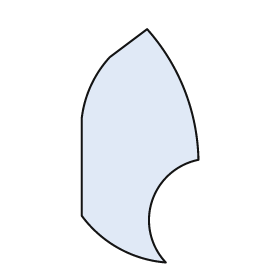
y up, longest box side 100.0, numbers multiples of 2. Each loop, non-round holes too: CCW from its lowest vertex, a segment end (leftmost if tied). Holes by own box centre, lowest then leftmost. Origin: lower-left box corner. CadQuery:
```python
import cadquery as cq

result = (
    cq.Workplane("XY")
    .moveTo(36.0, 0.0)
    .threePointArc((30.0, 26.0), (50.0, 44.0))
    .threePointArc((44.0, 74.0), (28.0, 100.0))
    .lineTo(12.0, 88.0)
    .threePointArc((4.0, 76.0), (0.0, 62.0))
    .lineTo(0.0, 20.0)
    .threePointArc((16.0, 6.0), (36.0, 0.0))
    .close()
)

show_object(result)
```